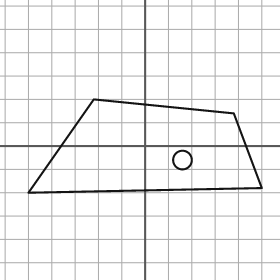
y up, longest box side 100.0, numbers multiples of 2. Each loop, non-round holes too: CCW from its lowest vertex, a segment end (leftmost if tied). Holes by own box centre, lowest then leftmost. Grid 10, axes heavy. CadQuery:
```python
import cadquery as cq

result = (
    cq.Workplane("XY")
    .moveTo(-50.0, -20.0)
    .lineTo(50.0, -18.0)
    .lineTo(38.0, 14.0)
    .lineTo(-22.0, 20.0)
    .close()
    .moveTo(16.0, -6.0)
    .circle(4.0)
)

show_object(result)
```